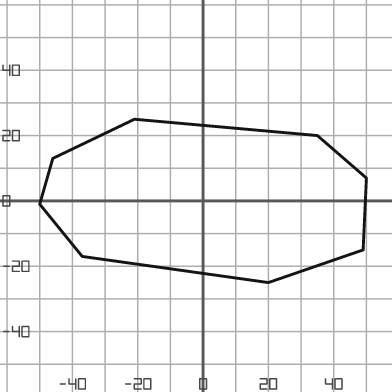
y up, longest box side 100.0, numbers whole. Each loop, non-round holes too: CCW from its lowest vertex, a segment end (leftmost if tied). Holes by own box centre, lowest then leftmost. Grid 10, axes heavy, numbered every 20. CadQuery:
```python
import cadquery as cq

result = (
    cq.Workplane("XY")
    .moveTo(20.0, -25.0)
    .lineTo(49.0, -15.0)
    .lineTo(50.0, 7.0)
    .lineTo(35.0, 20.0)
    .lineTo(-21.0, 25.0)
    .lineTo(-46.0, 13.0)
    .lineTo(-50.0, -1.0)
    .lineTo(-37.0, -17.0)
    .close()
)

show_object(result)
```